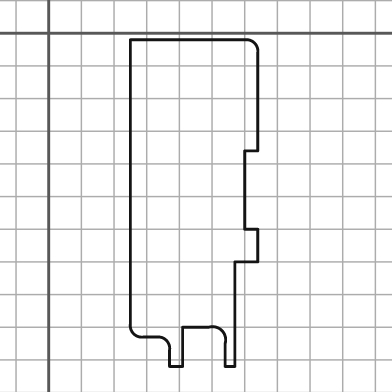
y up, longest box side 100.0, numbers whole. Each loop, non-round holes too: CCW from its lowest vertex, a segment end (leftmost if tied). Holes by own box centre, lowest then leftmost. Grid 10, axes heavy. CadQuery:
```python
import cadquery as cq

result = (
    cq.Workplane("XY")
    .moveTo(37.0, -102.0)
    .lineTo(41.0, -102.0)
    .lineTo(41.0, -90.0)
    .lineTo(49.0, -90.0)
    .threePointArc((53.0, -91.0), (54.0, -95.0))
    .lineTo(54.0, -102.0)
    .lineTo(57.0, -102.0)
    .lineTo(57.0, -70.0)
    .lineTo(64.0, -70.0)
    .lineTo(64.0, -60.0)
    .lineTo(60.0, -60.0)
    .lineTo(60.0, -36.0)
    .lineTo(64.0, -36.0)
    .lineTo(64.0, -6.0)
    .threePointArc((63.0, -3.0), (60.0, -2.0))
    .lineTo(25.0, -2.0)
    .lineTo(25.0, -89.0)
    .threePointArc((26.0, -92.0), (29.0, -93.0))
    .lineTo(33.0, -93.0)
    .threePointArc((36.0, -94.0), (37.0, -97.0))
    .close()
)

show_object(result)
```